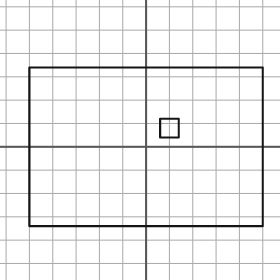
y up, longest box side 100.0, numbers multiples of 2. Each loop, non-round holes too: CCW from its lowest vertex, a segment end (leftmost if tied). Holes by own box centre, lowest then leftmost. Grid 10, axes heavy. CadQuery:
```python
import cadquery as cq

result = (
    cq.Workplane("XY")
    .moveTo(-50.0, -34.0)
    .lineTo(50.0, -34.0)
    .lineTo(50.0, 34.0)
    .lineTo(-50.0, 34.0)
    .close()
    .moveTo(6.0, 4.0)
    .lineTo(14.0, 4.0)
    .lineTo(14.0, 12.0)
    .lineTo(6.0, 12.0)
    .close()
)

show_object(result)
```